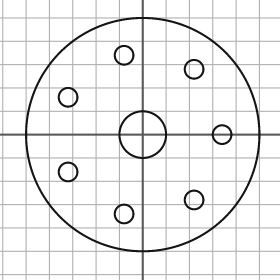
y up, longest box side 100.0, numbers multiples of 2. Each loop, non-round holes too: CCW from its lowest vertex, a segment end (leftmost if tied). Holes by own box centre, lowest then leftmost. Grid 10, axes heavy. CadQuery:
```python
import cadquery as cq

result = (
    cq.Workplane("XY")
    .moveTo(0.0, 0.0)
    .circle(50.0)
    .moveTo(-8.0, -34.0)
    .circle(4.0)
    .moveTo(22.0, -28.0)
    .circle(4.0)
    .moveTo(-32.0, -16.0)
    .circle(4.0)
    .moveTo(0.0, 0.0)
    .circle(10.0)
    .moveTo(34.0, 0.0)
    .circle(4.0)
    .moveTo(-32.0, 16.0)
    .circle(4.0)
    .moveTo(22.0, 28.0)
    .circle(4.0)
    .moveTo(-8.0, 34.0)
    .circle(4.0)
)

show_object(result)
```